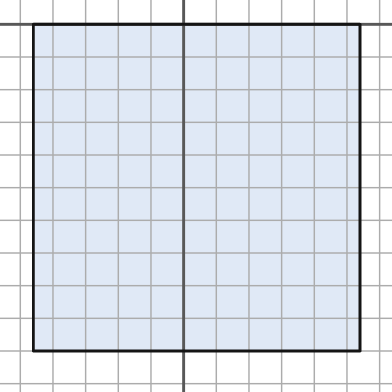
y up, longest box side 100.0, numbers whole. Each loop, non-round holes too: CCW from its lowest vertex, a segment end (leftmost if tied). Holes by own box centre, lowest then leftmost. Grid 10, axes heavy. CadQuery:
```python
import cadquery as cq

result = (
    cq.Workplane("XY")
    .moveTo(-46.0, -100.0)
    .lineTo(54.0, -100.0)
    .lineTo(54.0, 0.0)
    .lineTo(-46.0, 0.0)
    .close()
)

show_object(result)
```